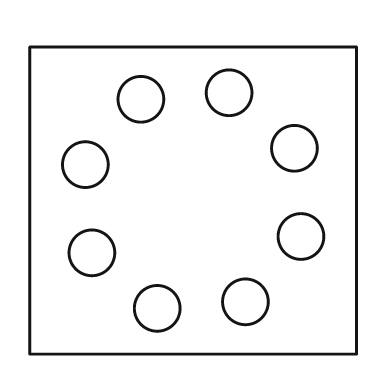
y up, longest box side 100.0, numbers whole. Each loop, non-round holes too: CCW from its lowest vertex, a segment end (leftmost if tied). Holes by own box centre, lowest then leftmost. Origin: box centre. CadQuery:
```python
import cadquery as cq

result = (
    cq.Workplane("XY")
    .moveTo(-50.0, -47.0)
    .lineTo(50.0, -47.0)
    .lineTo(50.0, 47.0)
    .lineTo(-50.0, 47.0)
    .close()
    .moveTo(-11.0, -33.0)
    .circle(7.0)
    .moveTo(16.0, -31.0)
    .circle(7.0)
    .moveTo(-31.0, -16.0)
    .circle(7.0)
    .moveTo(33.0, -11.0)
    .circle(7.0)
    .moveTo(-33.0, 11.0)
    .circle(7.0)
    .moveTo(31.0, 16.0)
    .circle(7.0)
    .moveTo(-16.0, 31.0)
    .circle(7.0)
    .moveTo(11.0, 33.0)
    .circle(7.0)
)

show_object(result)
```